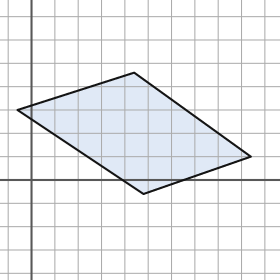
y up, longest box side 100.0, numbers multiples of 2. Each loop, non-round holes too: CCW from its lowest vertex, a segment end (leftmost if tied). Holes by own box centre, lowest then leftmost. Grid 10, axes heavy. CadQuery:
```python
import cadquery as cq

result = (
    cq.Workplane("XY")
    .moveTo(48.0, -6.0)
    .lineTo(94.0, 10.0)
    .lineTo(44.0, 46.0)
    .lineTo(-6.0, 30.0)
    .close()
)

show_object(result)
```